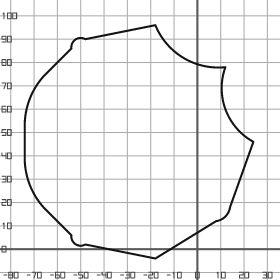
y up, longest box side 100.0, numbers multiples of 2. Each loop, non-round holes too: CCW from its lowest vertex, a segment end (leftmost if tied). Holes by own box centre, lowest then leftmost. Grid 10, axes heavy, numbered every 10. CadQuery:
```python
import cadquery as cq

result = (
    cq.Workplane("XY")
    .moveTo(-18.0, -4.0)
    .lineTo(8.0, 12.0)
    .threePointArc((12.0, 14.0), (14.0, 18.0))
    .lineTo(24.0, 46.0)
    .threePointArc((12.0, 60.0), (12.0, 78.0))
    .threePointArc((-6.0, 82.0), (-18.0, 96.0))
    .lineTo(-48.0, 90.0)
    .threePointArc((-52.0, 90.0), (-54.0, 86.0))
    .lineTo(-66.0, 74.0)
    .threePointArc((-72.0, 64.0), (-74.0, 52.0))
    .lineTo(-74.0, 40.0)
    .threePointArc((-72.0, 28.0), (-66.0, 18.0))
    .lineTo(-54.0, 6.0)
    .threePointArc((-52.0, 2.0), (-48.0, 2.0))
    .close()
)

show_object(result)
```